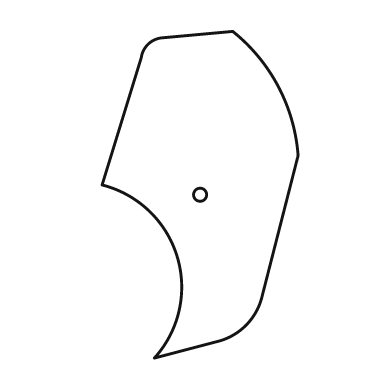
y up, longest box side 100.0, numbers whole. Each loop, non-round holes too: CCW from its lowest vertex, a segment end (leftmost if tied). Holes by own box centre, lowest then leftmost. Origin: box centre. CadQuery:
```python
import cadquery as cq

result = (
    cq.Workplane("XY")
    .moveTo(-14.0, -50.0)
    .lineTo(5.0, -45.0)
    .threePointArc((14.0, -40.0), (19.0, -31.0))
    .lineTo(30.0, 12.0)
    .threePointArc((24.0, 33.0), (10.0, 50.0))
    .lineTo(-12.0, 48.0)
    .threePointArc((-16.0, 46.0), (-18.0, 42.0))
    .lineTo(-30.0, 3.0)
    .threePointArc((-7.0, -19.0), (-14.0, -50.0))
    .close()
    .moveTo(0.0, 0.0)
    .circle(2.0)
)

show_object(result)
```